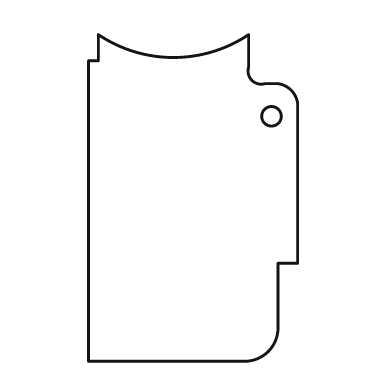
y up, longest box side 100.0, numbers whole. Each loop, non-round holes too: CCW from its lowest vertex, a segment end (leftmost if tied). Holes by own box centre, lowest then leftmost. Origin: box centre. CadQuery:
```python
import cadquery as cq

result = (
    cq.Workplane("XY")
    .moveTo(-32.0, -50.0)
    .lineTo(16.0, -50.0)
    .threePointArc((23.0, -47.0), (26.0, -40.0))
    .lineTo(26.0, -20.0)
    .lineTo(32.0, -20.0)
    .lineTo(32.0, 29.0)
    .threePointArc((30.0, 33.0), (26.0, 35.0))
    .lineTo(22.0, 35.0)
    .threePointArc((18.0, 36.0), (17.0, 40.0))
    .lineTo(17.0, 50.0)
    .threePointArc((-6.0, 43.0), (-29.0, 50.0))
    .lineTo(-29.0, 42.0)
    .lineTo(-32.0, 42.0)
    .close()
    .moveTo(24.0, 25.0)
    .circle(3.0)
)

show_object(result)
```